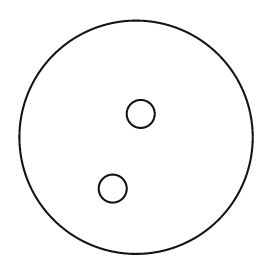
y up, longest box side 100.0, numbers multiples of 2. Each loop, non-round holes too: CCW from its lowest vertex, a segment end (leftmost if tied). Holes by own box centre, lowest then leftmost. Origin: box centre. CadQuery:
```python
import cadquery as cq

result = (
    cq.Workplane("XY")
    .moveTo(0.0, 0.0)
    .circle(50.0)
    .moveTo(-10.0, -22.0)
    .circle(6.0)
    .moveTo(2.0, 10.0)
    .circle(6.0)
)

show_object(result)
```